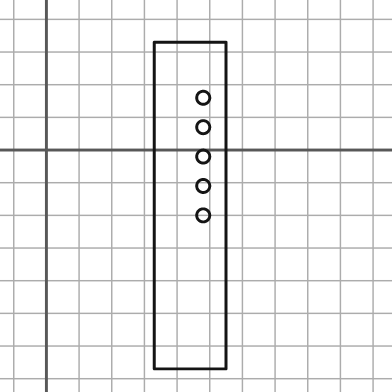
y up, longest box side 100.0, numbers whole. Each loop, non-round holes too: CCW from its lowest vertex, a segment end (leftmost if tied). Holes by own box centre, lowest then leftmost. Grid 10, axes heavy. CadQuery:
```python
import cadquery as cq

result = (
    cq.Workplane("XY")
    .moveTo(33.0, -67.0)
    .lineTo(55.0, -67.0)
    .lineTo(55.0, 33.0)
    .lineTo(33.0, 33.0)
    .close()
    .moveTo(48.0, -20.0)
    .circle(2.0)
    .moveTo(48.0, -11.0)
    .circle(2.0)
    .moveTo(48.0, -2.0)
    .circle(2.0)
    .moveTo(48.0, 7.0)
    .circle(2.0)
    .moveTo(48.0, 16.0)
    .circle(2.0)
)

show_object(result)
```